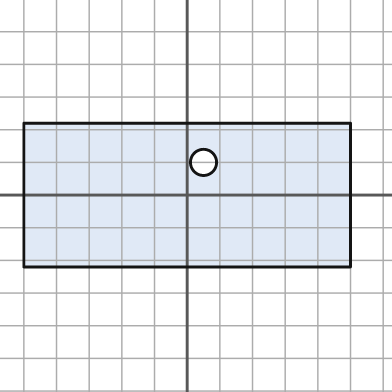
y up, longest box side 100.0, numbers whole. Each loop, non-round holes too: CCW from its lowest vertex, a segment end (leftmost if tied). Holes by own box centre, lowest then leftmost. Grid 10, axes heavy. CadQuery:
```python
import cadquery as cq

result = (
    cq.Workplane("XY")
    .moveTo(-50.0, -22.0)
    .lineTo(50.0, -22.0)
    .lineTo(50.0, 22.0)
    .lineTo(-50.0, 22.0)
    .close()
    .moveTo(5.0, 10.0)
    .circle(4.0)
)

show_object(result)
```